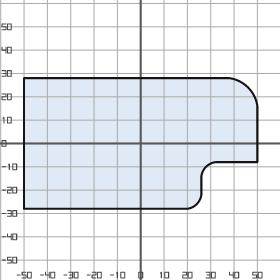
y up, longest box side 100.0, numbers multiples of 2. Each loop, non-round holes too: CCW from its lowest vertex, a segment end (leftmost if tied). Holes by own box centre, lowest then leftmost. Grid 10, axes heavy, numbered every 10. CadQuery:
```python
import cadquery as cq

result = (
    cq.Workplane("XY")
    .moveTo(-50.0, -28.0)
    .lineTo(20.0, -28.0)
    .threePointArc((24.0, -26.0), (26.0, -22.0))
    .lineTo(26.0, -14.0)
    .threePointArc((28.0, -10.0), (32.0, -8.0))
    .lineTo(50.0, -8.0)
    .lineTo(50.0, 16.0)
    .threePointArc((46.0, 24.0), (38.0, 28.0))
    .lineTo(-50.0, 28.0)
    .close()
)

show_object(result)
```